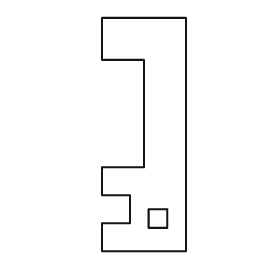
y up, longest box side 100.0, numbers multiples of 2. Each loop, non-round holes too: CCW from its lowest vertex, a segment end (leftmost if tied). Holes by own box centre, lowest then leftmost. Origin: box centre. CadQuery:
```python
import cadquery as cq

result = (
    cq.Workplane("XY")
    .moveTo(-18.0, -50.0)
    .lineTo(18.0, -50.0)
    .lineTo(18.0, 50.0)
    .lineTo(-18.0, 50.0)
    .lineTo(-18.0, 32.0)
    .lineTo(0.0, 32.0)
    .lineTo(0.0, -14.0)
    .lineTo(-18.0, -14.0)
    .lineTo(-18.0, -26.0)
    .lineTo(-6.0, -26.0)
    .lineTo(-6.0, -38.0)
    .lineTo(-18.0, -38.0)
    .close()
    .moveTo(2.0, -40.0)
    .lineTo(10.0, -40.0)
    .lineTo(10.0, -32.0)
    .lineTo(2.0, -32.0)
    .close()
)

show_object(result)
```